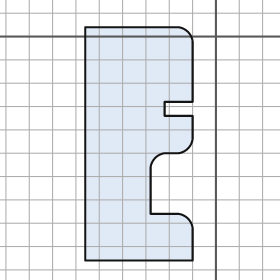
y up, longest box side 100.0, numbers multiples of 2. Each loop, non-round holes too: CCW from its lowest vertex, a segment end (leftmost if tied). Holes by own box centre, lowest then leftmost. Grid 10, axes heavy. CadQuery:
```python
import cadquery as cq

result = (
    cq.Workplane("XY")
    .moveTo(-56.0, -96.0)
    .lineTo(-10.0, -96.0)
    .lineTo(-10.0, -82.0)
    .threePointArc((-12.0, -78.0), (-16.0, -76.0))
    .lineTo(-28.0, -76.0)
    .lineTo(-28.0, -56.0)
    .threePointArc((-26.0, -52.0), (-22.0, -50.0))
    .lineTo(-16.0, -50.0)
    .threePointArc((-12.0, -48.0), (-10.0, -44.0))
    .lineTo(-10.0, -34.0)
    .lineTo(-22.0, -34.0)
    .lineTo(-22.0, -28.0)
    .lineTo(-10.0, -28.0)
    .lineTo(-10.0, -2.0)
    .threePointArc((-12.0, 2.0), (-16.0, 4.0))
    .lineTo(-56.0, 4.0)
    .close()
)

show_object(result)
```